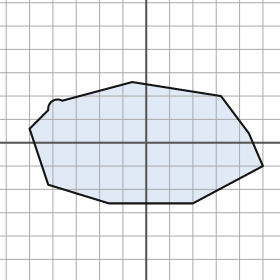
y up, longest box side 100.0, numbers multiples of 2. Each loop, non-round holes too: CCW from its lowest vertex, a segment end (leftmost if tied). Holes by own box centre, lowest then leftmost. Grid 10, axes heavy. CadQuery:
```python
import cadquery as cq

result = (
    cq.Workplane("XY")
    .moveTo(-16.0, -26.0)
    .lineTo(20.0, -26.0)
    .lineTo(50.0, -10.0)
    .lineTo(44.0, 4.0)
    .lineTo(32.0, 20.0)
    .lineTo(-6.0, 26.0)
    .lineTo(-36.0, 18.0)
    .threePointArc((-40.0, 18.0), (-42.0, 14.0))
    .lineTo(-50.0, 6.0)
    .lineTo(-42.0, -18.0)
    .close()
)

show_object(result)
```